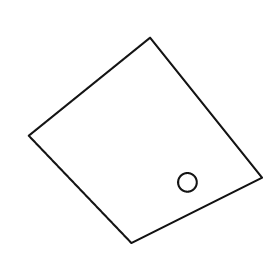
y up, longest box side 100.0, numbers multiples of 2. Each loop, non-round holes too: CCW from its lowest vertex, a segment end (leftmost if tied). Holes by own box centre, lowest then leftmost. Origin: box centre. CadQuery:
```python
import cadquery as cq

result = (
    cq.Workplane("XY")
    .moveTo(-6.0, -44.0)
    .lineTo(50.0, -16.0)
    .lineTo(2.0, 44.0)
    .lineTo(-50.0, 2.0)
    .close()
    .moveTo(18.0, -18.0)
    .circle(4.0)
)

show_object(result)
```